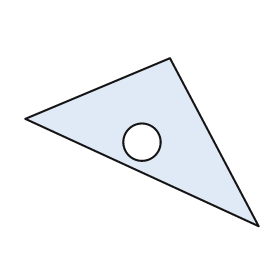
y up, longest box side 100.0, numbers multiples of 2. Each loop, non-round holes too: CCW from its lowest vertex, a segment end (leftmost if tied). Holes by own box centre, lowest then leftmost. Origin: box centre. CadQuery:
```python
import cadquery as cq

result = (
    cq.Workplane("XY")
    .moveTo(50.0, -36.0)
    .lineTo(12.0, 36.0)
    .lineTo(-50.0, 10.0)
    .close()
    .moveTo(0.0, 0.0)
    .circle(8.0)
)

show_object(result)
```